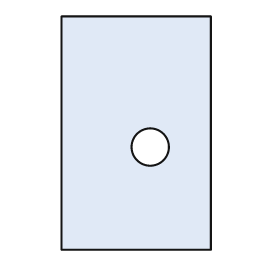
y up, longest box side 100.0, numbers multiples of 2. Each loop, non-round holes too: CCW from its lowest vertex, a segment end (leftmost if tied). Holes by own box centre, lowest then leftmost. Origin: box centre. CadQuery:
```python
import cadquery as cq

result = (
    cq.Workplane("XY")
    .moveTo(-32.0, -50.0)
    .lineTo(32.0, -50.0)
    .lineTo(32.0, 50.0)
    .lineTo(-32.0, 50.0)
    .close()
    .moveTo(6.0, -6.0)
    .circle(8.0)
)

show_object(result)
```